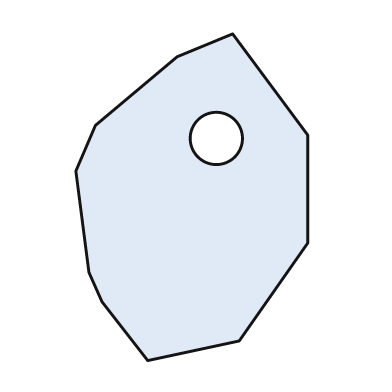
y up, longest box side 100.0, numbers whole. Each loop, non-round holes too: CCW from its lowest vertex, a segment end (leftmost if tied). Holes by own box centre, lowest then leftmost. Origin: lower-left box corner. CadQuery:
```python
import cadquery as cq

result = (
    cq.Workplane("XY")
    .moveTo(22.0, 0.0)
    .lineTo(50.0, 6.0)
    .lineTo(71.0, 36.0)
    .lineTo(71.0, 69.0)
    .lineTo(48.0, 100.0)
    .lineTo(31.0, 93.0)
    .lineTo(6.0, 72.0)
    .lineTo(0.0, 58.0)
    .lineTo(4.0, 27.0)
    .lineTo(8.0, 18.0)
    .close()
    .moveTo(43.0, 68.0)
    .circle(8.0)
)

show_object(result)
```